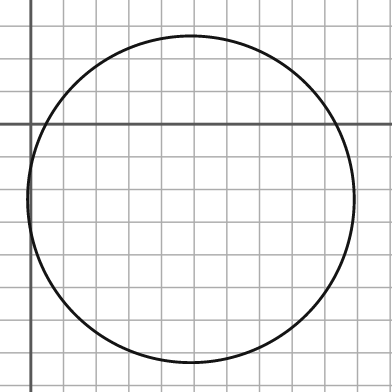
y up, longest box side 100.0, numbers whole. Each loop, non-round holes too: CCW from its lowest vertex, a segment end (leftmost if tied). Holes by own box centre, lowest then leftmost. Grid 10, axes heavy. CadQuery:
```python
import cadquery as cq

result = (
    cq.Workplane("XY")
    .moveTo(49.0, -23.0)
    .circle(50.0)
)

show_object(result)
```